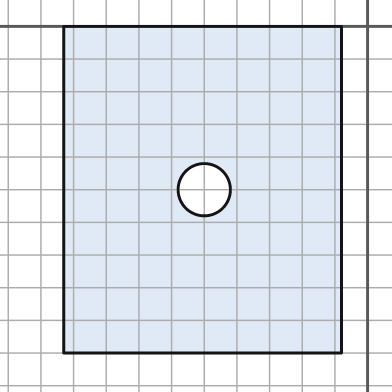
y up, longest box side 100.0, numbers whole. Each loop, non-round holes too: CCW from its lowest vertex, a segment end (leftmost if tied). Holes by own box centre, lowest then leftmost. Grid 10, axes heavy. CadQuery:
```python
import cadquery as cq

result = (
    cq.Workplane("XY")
    .moveTo(-93.0, -100.0)
    .lineTo(-8.0, -100.0)
    .lineTo(-8.0, 0.0)
    .lineTo(-93.0, 0.0)
    .close()
    .moveTo(-50.0, -50.0)
    .circle(8.0)
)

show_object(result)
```